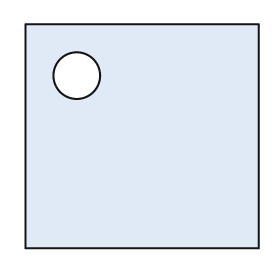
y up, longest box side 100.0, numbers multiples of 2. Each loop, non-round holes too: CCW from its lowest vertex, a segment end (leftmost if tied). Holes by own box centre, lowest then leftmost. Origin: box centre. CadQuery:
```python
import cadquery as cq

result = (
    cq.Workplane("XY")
    .moveTo(-50.0, -48.0)
    .lineTo(50.0, -48.0)
    .lineTo(50.0, 48.0)
    .lineTo(-50.0, 48.0)
    .close()
    .moveTo(-28.0, 26.0)
    .circle(10.0)
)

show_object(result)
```